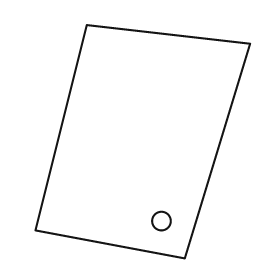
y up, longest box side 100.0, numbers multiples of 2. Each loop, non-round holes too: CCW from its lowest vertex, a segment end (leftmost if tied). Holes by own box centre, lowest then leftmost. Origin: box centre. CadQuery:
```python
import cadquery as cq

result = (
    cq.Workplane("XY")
    .moveTo(18.0, -50.0)
    .lineTo(46.0, 42.0)
    .lineTo(-24.0, 50.0)
    .lineTo(-46.0, -38.0)
    .close()
    .moveTo(8.0, -34.0)
    .circle(4.0)
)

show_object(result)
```